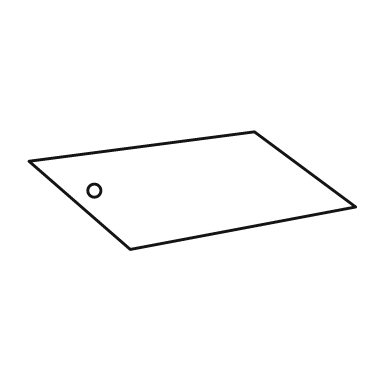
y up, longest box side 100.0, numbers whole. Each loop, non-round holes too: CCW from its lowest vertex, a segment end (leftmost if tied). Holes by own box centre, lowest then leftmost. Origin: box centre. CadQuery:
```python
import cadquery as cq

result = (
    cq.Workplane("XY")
    .moveTo(-19.0, -18.0)
    .lineTo(50.0, -5.0)
    .lineTo(19.0, 18.0)
    .lineTo(-50.0, 9.0)
    .close()
    .moveTo(-30.0, 0.0)
    .circle(2.0)
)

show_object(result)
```